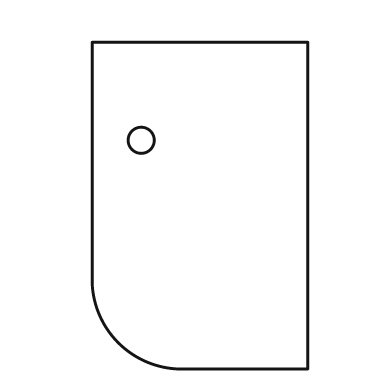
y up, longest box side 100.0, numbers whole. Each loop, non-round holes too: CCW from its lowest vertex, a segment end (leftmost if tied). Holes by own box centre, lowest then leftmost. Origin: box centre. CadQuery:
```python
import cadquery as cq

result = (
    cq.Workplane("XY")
    .moveTo(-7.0, -50.0)
    .lineTo(33.0, -50.0)
    .lineTo(33.0, 50.0)
    .lineTo(-33.0, 50.0)
    .lineTo(-33.0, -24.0)
    .threePointArc((-25.0, -42.0), (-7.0, -50.0))
    .close()
    .moveTo(-18.0, 20.0)
    .circle(4.0)
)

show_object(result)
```